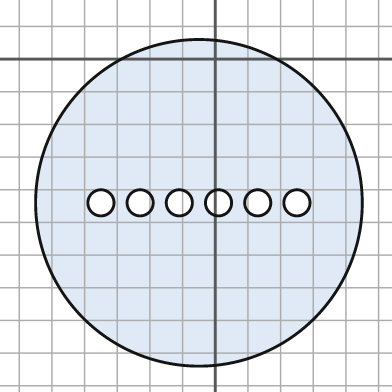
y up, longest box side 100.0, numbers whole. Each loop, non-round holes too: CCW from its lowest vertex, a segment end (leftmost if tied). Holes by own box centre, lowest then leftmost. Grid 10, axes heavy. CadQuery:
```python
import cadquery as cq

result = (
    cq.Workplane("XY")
    .moveTo(-5.0, -44.0)
    .circle(50.0)
    .moveTo(-35.0, -44.0)
    .circle(4.0)
    .moveTo(-23.0, -44.0)
    .circle(4.0)
    .moveTo(-11.0, -44.0)
    .circle(4.0)
    .moveTo(1.0, -44.0)
    .circle(4.0)
    .moveTo(13.0, -44.0)
    .circle(4.0)
    .moveTo(25.0, -44.0)
    .circle(4.0)
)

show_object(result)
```